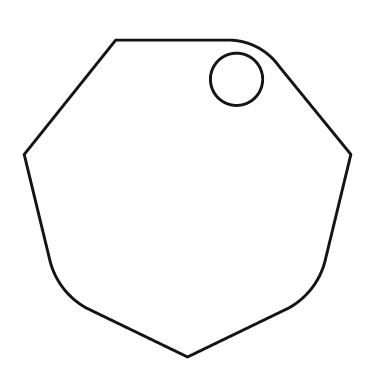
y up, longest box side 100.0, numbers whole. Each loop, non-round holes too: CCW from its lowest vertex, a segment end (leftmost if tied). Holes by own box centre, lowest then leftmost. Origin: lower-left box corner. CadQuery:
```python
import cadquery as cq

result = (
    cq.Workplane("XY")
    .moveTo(50.0, 0.0)
    .lineTo(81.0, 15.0)
    .threePointArc((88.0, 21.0), (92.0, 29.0))
    .lineTo(100.0, 62.0)
    .lineTo(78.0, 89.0)
    .threePointArc((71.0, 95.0), (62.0, 97.0))
    .lineTo(28.0, 97.0)
    .lineTo(0.0, 62.0)
    .lineTo(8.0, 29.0)
    .threePointArc((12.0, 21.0), (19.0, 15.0))
    .close()
    .moveTo(65.0, 85.0)
    .circle(8.0)
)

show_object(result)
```